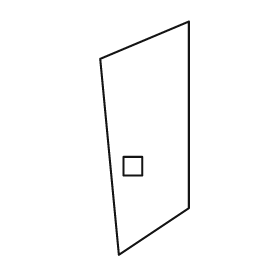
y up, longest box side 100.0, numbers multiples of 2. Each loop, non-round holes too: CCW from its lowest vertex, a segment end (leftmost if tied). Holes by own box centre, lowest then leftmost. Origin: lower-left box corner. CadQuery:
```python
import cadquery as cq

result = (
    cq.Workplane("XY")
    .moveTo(8.0, 0.0)
    .lineTo(38.0, 20.0)
    .lineTo(38.0, 100.0)
    .lineTo(0.0, 84.0)
    .close()
    .moveTo(10.0, 34.0)
    .lineTo(18.0, 34.0)
    .lineTo(18.0, 42.0)
    .lineTo(10.0, 42.0)
    .close()
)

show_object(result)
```